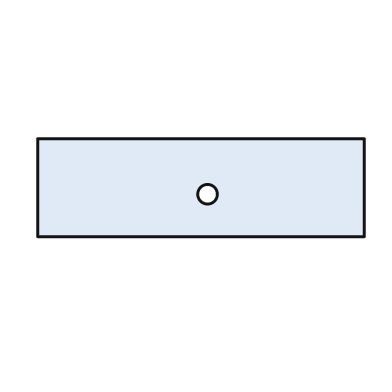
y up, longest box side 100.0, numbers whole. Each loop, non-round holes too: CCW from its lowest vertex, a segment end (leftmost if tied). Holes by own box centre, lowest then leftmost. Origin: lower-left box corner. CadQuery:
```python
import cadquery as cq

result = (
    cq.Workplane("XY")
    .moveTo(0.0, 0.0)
    .lineTo(100.0, 0.0)
    .lineTo(100.0, 30.0)
    .lineTo(0.0, 30.0)
    .close()
    .moveTo(52.0, 13.0)
    .circle(3.0)
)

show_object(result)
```